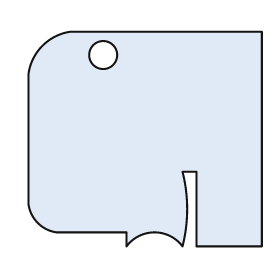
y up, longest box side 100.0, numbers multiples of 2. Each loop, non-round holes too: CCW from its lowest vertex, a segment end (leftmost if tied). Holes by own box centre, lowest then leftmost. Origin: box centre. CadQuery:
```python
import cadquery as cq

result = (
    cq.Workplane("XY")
    .moveTo(-8.0, -46.0)
    .threePointArc((4.0, -40.0), (16.0, -46.0))
    .threePointArc((18.0, -30.0), (16.0, -14.0))
    .lineTo(22.0, -14.0)
    .lineTo(22.0, -46.0)
    .lineTo(50.0, -46.0)
    .lineTo(50.0, 46.0)
    .lineTo(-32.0, 46.0)
    .threePointArc((-44.0, 40.0), (-50.0, 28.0))
    .lineTo(-50.0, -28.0)
    .threePointArc((-46.0, -36.0), (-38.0, -40.0))
    .lineTo(-8.0, -40.0)
    .close()
    .moveTo(-18.0, 36.0)
    .circle(6.0)
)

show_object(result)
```